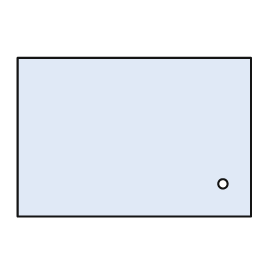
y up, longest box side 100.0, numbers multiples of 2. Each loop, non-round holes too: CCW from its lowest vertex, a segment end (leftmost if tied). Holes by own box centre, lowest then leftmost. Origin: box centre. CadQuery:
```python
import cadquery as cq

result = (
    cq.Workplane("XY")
    .moveTo(-50.0, -34.0)
    .lineTo(50.0, -34.0)
    .lineTo(50.0, 34.0)
    .lineTo(-50.0, 34.0)
    .close()
    .moveTo(38.0, -20.0)
    .circle(2.0)
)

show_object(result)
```